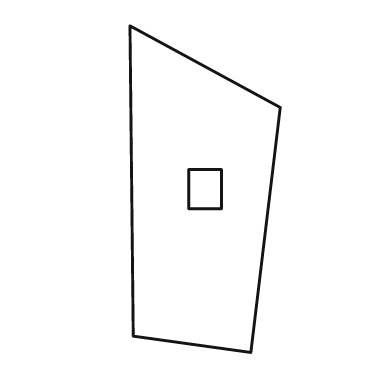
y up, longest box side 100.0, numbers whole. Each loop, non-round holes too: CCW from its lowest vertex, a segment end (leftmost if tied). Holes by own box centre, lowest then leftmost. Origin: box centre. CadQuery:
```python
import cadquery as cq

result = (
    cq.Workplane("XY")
    .moveTo(14.0, -50.0)
    .lineTo(23.0, 25.0)
    .lineTo(-23.0, 50.0)
    .lineTo(-22.0, -45.0)
    .close()
    .moveTo(-5.0, -6.0)
    .lineTo(5.0, -6.0)
    .lineTo(5.0, 6.0)
    .lineTo(-5.0, 6.0)
    .close()
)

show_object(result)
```